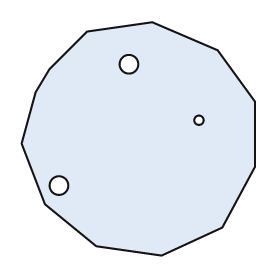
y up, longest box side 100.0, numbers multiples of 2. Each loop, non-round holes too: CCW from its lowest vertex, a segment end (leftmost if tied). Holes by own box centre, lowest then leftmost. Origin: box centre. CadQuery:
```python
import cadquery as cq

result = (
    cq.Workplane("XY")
    .moveTo(10.0, -50.0)
    .lineTo(36.0, -38.0)
    .lineTo(50.0, -12.0)
    .lineTo(50.0, 16.0)
    .lineTo(34.0, 38.0)
    .lineTo(6.0, 50.0)
    .lineTo(-22.0, 46.0)
    .lineTo(-38.0, 30.0)
    .lineTo(-44.0, 20.0)
    .lineTo(-50.0, -2.0)
    .lineTo(-40.0, -28.0)
    .lineTo(-18.0, -46.0)
    .close()
    .moveTo(-34.0, -20.0)
    .circle(4.0)
    .moveTo(26.0, 8.0)
    .circle(2.0)
    .moveTo(-4.0, 32.0)
    .circle(4.0)
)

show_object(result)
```